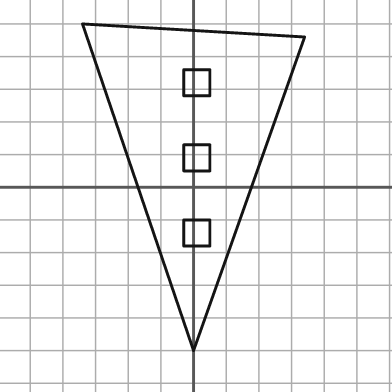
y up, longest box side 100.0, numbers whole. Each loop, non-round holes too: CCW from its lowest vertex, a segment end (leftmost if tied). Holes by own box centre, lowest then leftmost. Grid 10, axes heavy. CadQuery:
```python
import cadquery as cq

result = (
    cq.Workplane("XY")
    .moveTo(0.0, -50.0)
    .lineTo(34.0, 46.0)
    .lineTo(-34.0, 50.0)
    .close()
    .moveTo(-3.0, -18.0)
    .lineTo(5.0, -18.0)
    .lineTo(5.0, -10.0)
    .lineTo(-3.0, -10.0)
    .close()
    .moveTo(-3.0, 5.0)
    .lineTo(5.0, 5.0)
    .lineTo(5.0, 13.0)
    .lineTo(-3.0, 13.0)
    .close()
    .moveTo(-3.0, 28.0)
    .lineTo(5.0, 28.0)
    .lineTo(5.0, 36.0)
    .lineTo(-3.0, 36.0)
    .close()
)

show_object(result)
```